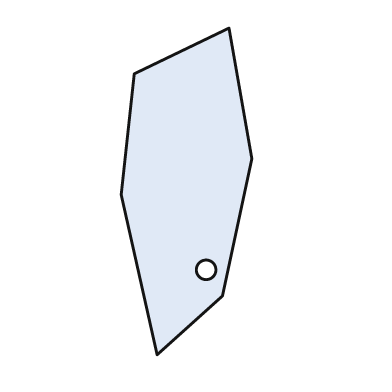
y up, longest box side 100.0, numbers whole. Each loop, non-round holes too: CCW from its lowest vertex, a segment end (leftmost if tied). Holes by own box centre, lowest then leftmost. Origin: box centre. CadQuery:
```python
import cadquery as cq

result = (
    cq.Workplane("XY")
    .moveTo(-9.0, -50.0)
    .lineTo(11.0, -32.0)
    .lineTo(20.0, 10.0)
    .lineTo(13.0, 50.0)
    .lineTo(-16.0, 36.0)
    .lineTo(-20.0, -1.0)
    .close()
    .moveTo(6.0, -24.0)
    .circle(3.0)
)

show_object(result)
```